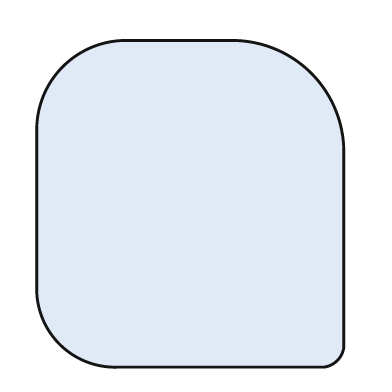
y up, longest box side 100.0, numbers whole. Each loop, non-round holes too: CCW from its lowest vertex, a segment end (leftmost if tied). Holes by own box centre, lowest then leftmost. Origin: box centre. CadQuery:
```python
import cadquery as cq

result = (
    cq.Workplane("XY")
    .moveTo(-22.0, -50.0)
    .lineTo(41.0, -50.0)
    .threePointArc((45.0, -48.0), (47.0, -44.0))
    .lineTo(47.0, 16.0)
    .threePointArc((37.0, 40.0), (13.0, 50.0))
    .lineTo(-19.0, 50.0)
    .threePointArc((-39.0, 42.0), (-47.0, 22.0))
    .lineTo(-47.0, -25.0)
    .threePointArc((-40.0, -43.0), (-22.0, -50.0))
    .close()
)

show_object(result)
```